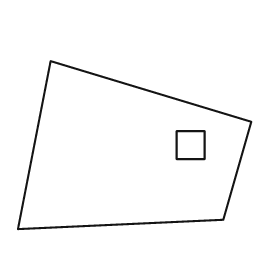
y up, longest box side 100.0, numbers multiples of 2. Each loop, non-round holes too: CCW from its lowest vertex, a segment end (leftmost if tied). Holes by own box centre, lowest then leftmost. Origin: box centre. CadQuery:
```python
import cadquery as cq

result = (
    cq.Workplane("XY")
    .moveTo(-50.0, -36.0)
    .lineTo(38.0, -32.0)
    .lineTo(50.0, 10.0)
    .lineTo(-36.0, 36.0)
    .close()
    .moveTo(18.0, -6.0)
    .lineTo(30.0, -6.0)
    .lineTo(30.0, 6.0)
    .lineTo(18.0, 6.0)
    .close()
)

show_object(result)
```